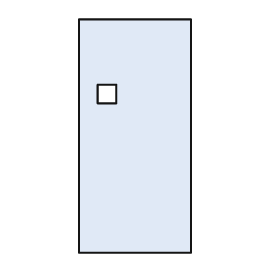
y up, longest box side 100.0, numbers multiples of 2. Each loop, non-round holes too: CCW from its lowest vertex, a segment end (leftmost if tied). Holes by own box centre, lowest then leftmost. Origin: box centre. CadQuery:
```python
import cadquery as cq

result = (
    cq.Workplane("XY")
    .moveTo(-24.0, -50.0)
    .lineTo(24.0, -50.0)
    .lineTo(24.0, 50.0)
    .lineTo(-24.0, 50.0)
    .close()
    .moveTo(-16.0, 14.0)
    .lineTo(-8.0, 14.0)
    .lineTo(-8.0, 22.0)
    .lineTo(-16.0, 22.0)
    .close()
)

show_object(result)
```